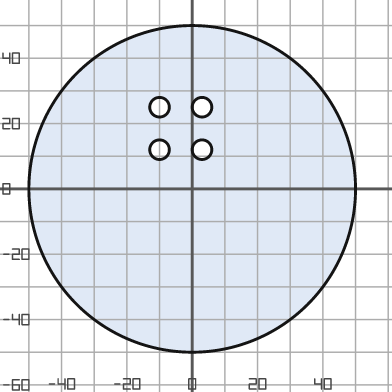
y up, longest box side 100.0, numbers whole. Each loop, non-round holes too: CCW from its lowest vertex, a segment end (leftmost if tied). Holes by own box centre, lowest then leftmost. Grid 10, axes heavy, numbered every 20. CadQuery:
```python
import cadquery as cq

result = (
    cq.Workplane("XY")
    .moveTo(0.0, 0.0)
    .circle(50.0)
    .moveTo(-10.0, 12.0)
    .circle(3.0)
    .moveTo(3.0, 12.0)
    .circle(3.0)
    .moveTo(-10.0, 25.0)
    .circle(3.0)
    .moveTo(3.0, 25.0)
    .circle(3.0)
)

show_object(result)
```